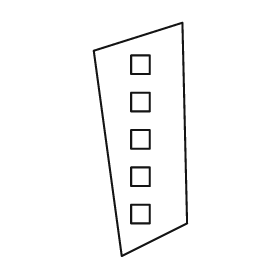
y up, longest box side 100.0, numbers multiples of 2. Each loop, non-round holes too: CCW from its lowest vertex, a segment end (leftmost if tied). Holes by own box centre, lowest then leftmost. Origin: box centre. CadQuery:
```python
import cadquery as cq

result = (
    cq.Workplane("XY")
    .moveTo(-8.0, -50.0)
    .lineTo(20.0, -36.0)
    .lineTo(18.0, 50.0)
    .lineTo(-20.0, 38.0)
    .close()
    .moveTo(-4.0, -36.0)
    .lineTo(4.0, -36.0)
    .lineTo(4.0, -28.0)
    .lineTo(-4.0, -28.0)
    .close()
    .moveTo(-4.0, -20.0)
    .lineTo(4.0, -20.0)
    .lineTo(4.0, -12.0)
    .lineTo(-4.0, -12.0)
    .close()
    .moveTo(-4.0, -4.0)
    .lineTo(4.0, -4.0)
    .lineTo(4.0, 4.0)
    .lineTo(-4.0, 4.0)
    .close()
    .moveTo(-4.0, 12.0)
    .lineTo(4.0, 12.0)
    .lineTo(4.0, 20.0)
    .lineTo(-4.0, 20.0)
    .close()
    .moveTo(-4.0, 28.0)
    .lineTo(4.0, 28.0)
    .lineTo(4.0, 36.0)
    .lineTo(-4.0, 36.0)
    .close()
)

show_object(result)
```